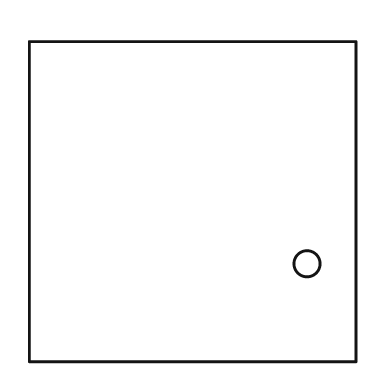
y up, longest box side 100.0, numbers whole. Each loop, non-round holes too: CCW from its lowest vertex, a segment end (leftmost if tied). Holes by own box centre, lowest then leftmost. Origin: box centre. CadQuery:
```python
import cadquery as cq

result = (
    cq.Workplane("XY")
    .moveTo(-50.0, -49.0)
    .lineTo(50.0, -49.0)
    .lineTo(50.0, 49.0)
    .lineTo(-50.0, 49.0)
    .close()
    .moveTo(35.0, -19.0)
    .circle(4.0)
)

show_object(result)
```